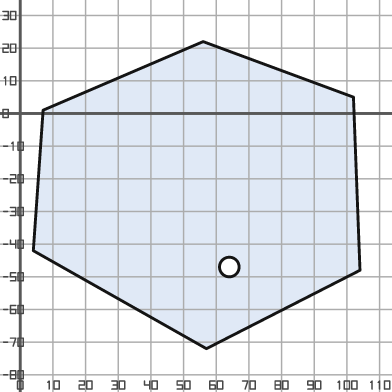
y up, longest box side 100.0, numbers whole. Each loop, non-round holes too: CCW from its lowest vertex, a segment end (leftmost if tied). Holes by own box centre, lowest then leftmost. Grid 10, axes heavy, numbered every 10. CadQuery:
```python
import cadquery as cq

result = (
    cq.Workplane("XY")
    .moveTo(57.0, -72.0)
    .lineTo(104.0, -48.0)
    .lineTo(102.0, 5.0)
    .lineTo(56.0, 22.0)
    .lineTo(7.0, 1.0)
    .lineTo(4.0, -42.0)
    .close()
    .moveTo(64.0, -47.0)
    .circle(3.0)
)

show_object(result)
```